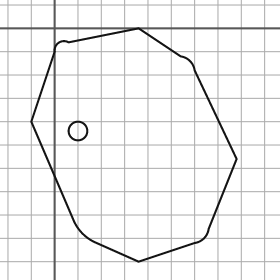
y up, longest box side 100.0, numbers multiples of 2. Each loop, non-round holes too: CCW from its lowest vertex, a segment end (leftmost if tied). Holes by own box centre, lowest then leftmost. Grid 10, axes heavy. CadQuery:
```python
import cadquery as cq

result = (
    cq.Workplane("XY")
    .moveTo(36.0, -100.0)
    .lineTo(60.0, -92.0)
    .threePointArc((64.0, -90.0), (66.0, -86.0))
    .lineTo(78.0, -56.0)
    .lineTo(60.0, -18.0)
    .threePointArc((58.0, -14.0), (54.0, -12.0))
    .lineTo(36.0, 0.0)
    .lineTo(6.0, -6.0)
    .threePointArc((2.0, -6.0), (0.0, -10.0))
    .lineTo(-10.0, -40.0)
    .lineTo(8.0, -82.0)
    .threePointArc((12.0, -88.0), (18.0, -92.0))
    .close()
    .moveTo(10.0, -44.0)
    .circle(4.0)
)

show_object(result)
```